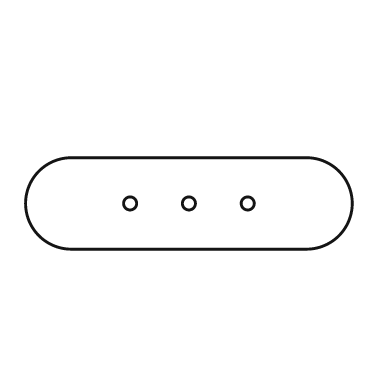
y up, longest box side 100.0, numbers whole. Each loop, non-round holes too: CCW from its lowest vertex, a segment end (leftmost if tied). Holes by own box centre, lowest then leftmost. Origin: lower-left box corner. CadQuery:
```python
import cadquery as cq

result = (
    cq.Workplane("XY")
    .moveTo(14.0, 0.0)
    .lineTo(86.0, 0.0)
    .threePointArc((100.0, 14.0), (86.0, 28.0))
    .lineTo(14.0, 28.0)
    .threePointArc((0.0, 14.0), (14.0, 0.0))
    .close()
    .moveTo(32.0, 14.0)
    .circle(2.0)
    .moveTo(50.0, 14.0)
    .circle(2.0)
    .moveTo(68.0, 14.0)
    .circle(2.0)
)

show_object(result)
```